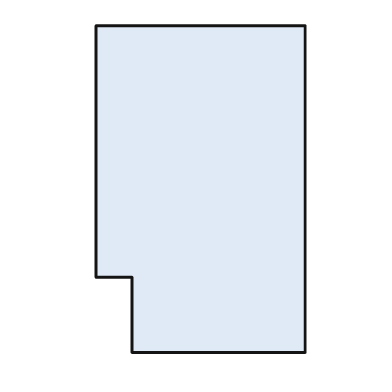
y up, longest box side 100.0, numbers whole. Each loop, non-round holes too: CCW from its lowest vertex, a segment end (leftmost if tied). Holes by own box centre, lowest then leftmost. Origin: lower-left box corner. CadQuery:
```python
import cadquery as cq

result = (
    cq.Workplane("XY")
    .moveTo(11.0, 0.0)
    .lineTo(64.0, 0.0)
    .lineTo(64.0, 100.0)
    .lineTo(0.0, 100.0)
    .lineTo(0.0, 23.0)
    .lineTo(11.0, 23.0)
    .close()
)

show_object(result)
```